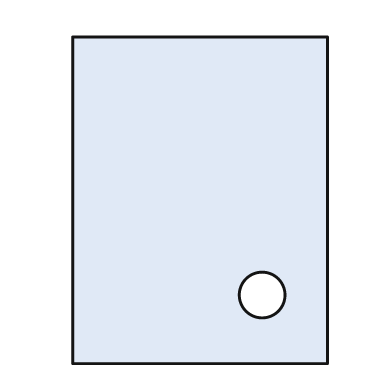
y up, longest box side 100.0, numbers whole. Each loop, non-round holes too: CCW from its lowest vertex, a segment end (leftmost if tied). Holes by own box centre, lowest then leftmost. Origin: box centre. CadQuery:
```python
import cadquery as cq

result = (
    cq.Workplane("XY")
    .moveTo(-39.0, -50.0)
    .lineTo(39.0, -50.0)
    .lineTo(39.0, 50.0)
    .lineTo(-39.0, 50.0)
    .close()
    .moveTo(19.0, -29.0)
    .circle(7.0)
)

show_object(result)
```